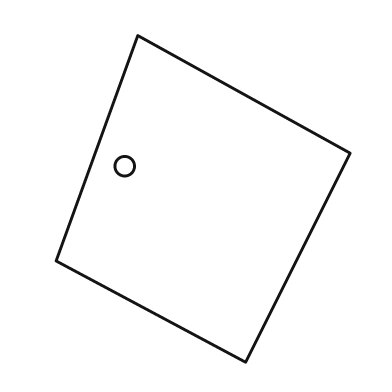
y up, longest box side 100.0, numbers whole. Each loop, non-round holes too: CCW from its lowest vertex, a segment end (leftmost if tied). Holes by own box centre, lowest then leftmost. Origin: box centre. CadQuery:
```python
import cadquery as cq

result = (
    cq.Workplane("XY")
    .moveTo(13.0, -50.0)
    .lineTo(45.0, 14.0)
    .lineTo(-20.0, 50.0)
    .lineTo(-45.0, -19.0)
    .close()
    .moveTo(-24.0, 10.0)
    .circle(3.0)
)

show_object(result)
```